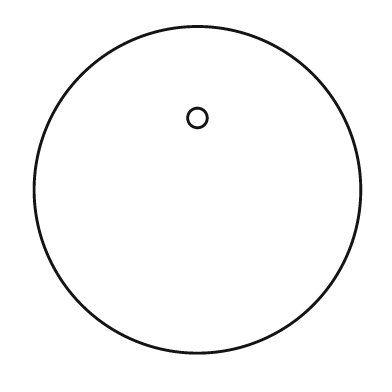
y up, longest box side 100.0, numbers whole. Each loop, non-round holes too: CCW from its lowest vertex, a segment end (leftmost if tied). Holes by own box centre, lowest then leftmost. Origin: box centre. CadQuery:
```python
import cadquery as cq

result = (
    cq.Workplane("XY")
    .moveTo(0.0, 0.0)
    .circle(50.0)
    .moveTo(0.0, 22.0)
    .circle(3.0)
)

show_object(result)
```